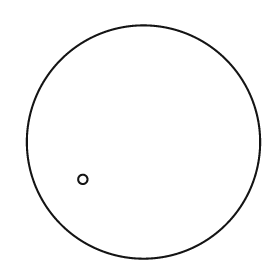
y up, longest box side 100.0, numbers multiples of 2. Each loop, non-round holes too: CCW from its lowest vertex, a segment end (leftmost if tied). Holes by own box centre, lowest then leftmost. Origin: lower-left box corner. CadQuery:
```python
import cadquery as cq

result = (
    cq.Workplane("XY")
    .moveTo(50.0, 50.0)
    .circle(50.0)
    .moveTo(24.0, 34.0)
    .circle(2.0)
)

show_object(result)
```